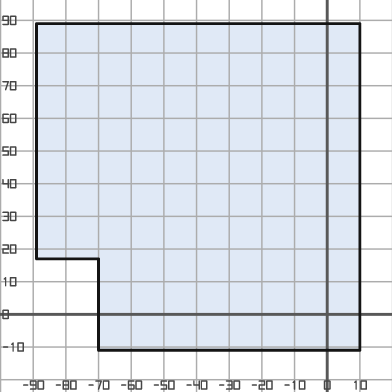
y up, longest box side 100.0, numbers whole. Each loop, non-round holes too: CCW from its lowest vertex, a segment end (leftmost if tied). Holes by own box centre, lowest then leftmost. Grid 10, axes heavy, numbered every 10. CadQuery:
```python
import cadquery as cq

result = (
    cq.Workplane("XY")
    .moveTo(-70.0, -11.0)
    .lineTo(10.0, -11.0)
    .lineTo(10.0, 89.0)
    .lineTo(-89.0, 89.0)
    .lineTo(-89.0, 17.0)
    .lineTo(-70.0, 17.0)
    .close()
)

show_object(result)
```